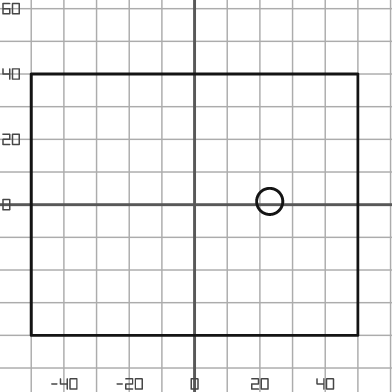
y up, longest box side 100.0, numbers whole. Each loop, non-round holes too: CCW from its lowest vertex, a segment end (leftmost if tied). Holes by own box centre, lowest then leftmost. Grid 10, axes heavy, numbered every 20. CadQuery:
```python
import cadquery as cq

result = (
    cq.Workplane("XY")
    .moveTo(-50.0, -40.0)
    .lineTo(50.0, -40.0)
    .lineTo(50.0, 40.0)
    .lineTo(-50.0, 40.0)
    .close()
    .moveTo(23.0, 1.0)
    .circle(4.0)
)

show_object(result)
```